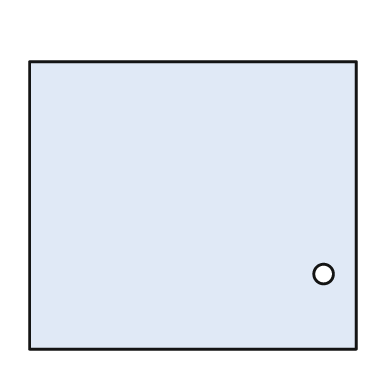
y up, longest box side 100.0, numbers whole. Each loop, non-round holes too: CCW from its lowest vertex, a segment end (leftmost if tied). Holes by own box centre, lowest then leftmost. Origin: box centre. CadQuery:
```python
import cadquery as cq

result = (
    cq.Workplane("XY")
    .moveTo(-50.0, -44.0)
    .lineTo(50.0, -44.0)
    .lineTo(50.0, 44.0)
    .lineTo(-50.0, 44.0)
    .close()
    .moveTo(40.0, -21.0)
    .circle(3.0)
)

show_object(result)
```